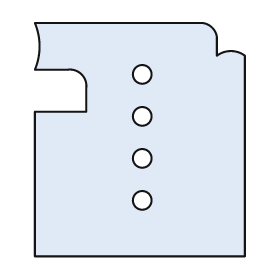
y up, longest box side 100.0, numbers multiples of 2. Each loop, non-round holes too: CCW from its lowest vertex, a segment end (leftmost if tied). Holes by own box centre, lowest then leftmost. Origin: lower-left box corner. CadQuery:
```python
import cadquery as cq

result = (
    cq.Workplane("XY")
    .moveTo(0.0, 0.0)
    .lineTo(90.0, 0.0)
    .lineTo(90.0, 86.0)
    .threePointArc((84.0, 88.0), (78.0, 86.0))
    .lineTo(78.0, 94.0)
    .threePointArc((76.0, 98.0), (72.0, 100.0))
    .lineTo(0.0, 100.0)
    .threePointArc((2.0, 90.0), (0.0, 80.0))
    .lineTo(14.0, 80.0)
    .threePointArc((20.0, 78.0), (22.0, 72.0))
    .lineTo(22.0, 62.0)
    .lineTo(0.0, 62.0)
    .close()
    .moveTo(46.0, 24.0)
    .circle(4.0)
    .moveTo(46.0, 42.0)
    .circle(4.0)
    .moveTo(46.0, 60.0)
    .circle(4.0)
    .moveTo(46.0, 78.0)
    .circle(4.0)
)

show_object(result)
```